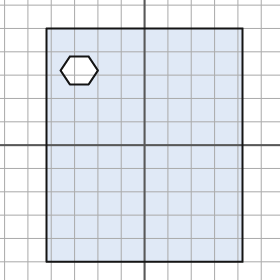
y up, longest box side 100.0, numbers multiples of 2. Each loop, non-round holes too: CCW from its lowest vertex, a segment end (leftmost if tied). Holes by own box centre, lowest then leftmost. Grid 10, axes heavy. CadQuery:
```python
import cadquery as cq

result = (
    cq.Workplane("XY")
    .moveTo(-42.0, -50.0)
    .lineTo(42.0, -50.0)
    .lineTo(42.0, 50.0)
    .lineTo(-42.0, 50.0)
    .close()
    .moveTo(-32.0, 26.0)
    .lineTo(-24.0, 26.0)
    .lineTo(-20.0, 32.0)
    .lineTo(-24.0, 38.0)
    .lineTo(-32.0, 38.0)
    .lineTo(-36.0, 32.0)
    .close()
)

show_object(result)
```